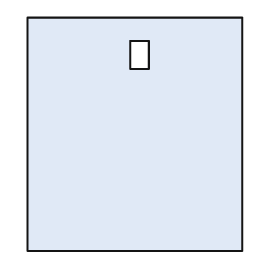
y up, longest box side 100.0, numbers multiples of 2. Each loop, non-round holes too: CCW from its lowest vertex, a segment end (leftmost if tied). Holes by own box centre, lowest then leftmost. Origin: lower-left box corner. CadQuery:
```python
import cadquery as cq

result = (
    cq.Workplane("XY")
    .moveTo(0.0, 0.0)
    .lineTo(92.0, 0.0)
    .lineTo(92.0, 100.0)
    .lineTo(0.0, 100.0)
    .close()
    .moveTo(44.0, 78.0)
    .lineTo(52.0, 78.0)
    .lineTo(52.0, 90.0)
    .lineTo(44.0, 90.0)
    .close()
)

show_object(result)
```